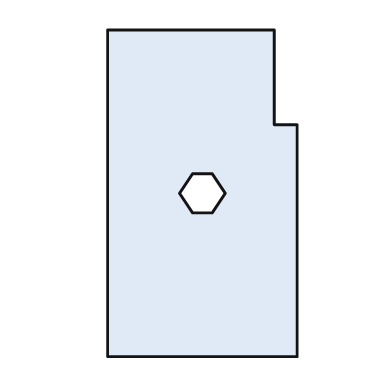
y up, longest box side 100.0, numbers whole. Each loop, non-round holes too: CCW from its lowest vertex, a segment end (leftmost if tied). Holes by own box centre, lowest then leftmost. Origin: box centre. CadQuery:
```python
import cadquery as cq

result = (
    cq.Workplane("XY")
    .moveTo(-29.0, -50.0)
    .lineTo(29.0, -50.0)
    .lineTo(29.0, 21.0)
    .lineTo(22.0, 21.0)
    .lineTo(22.0, 50.0)
    .lineTo(-29.0, 50.0)
    .close()
    .moveTo(-3.0, -6.0)
    .lineTo(3.0, -6.0)
    .lineTo(7.0, 0.0)
    .lineTo(3.0, 6.0)
    .lineTo(-3.0, 6.0)
    .lineTo(-7.0, 0.0)
    .close()
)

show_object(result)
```